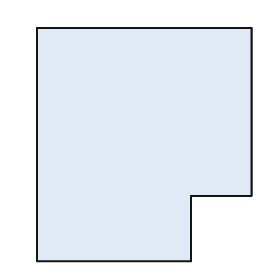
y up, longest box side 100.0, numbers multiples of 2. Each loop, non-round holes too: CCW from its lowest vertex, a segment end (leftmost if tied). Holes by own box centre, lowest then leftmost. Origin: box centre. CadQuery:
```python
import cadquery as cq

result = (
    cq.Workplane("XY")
    .moveTo(-46.0, -50.0)
    .lineTo(20.0, -50.0)
    .lineTo(20.0, -22.0)
    .lineTo(46.0, -22.0)
    .lineTo(46.0, 50.0)
    .lineTo(-46.0, 50.0)
    .close()
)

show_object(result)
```